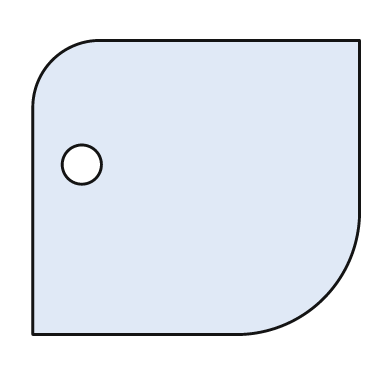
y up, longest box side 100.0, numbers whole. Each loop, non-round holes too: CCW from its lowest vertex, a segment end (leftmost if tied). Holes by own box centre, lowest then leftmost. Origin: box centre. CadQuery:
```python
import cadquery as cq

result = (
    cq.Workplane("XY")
    .moveTo(-50.0, -45.0)
    .lineTo(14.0, -45.0)
    .threePointArc((39.0, -34.0), (50.0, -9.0))
    .lineTo(50.0, 45.0)
    .lineTo(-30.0, 45.0)
    .threePointArc((-44.0, 39.0), (-50.0, 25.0))
    .close()
    .moveTo(-35.0, 7.0)
    .circle(6.0)
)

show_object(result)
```